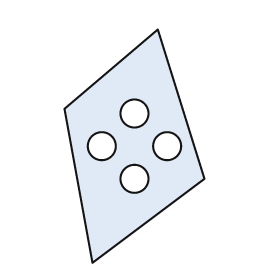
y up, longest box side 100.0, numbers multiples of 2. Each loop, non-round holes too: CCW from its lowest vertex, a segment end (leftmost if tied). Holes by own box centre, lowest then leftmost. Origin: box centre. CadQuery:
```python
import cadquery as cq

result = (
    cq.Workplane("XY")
    .moveTo(-18.0, -50.0)
    .lineTo(30.0, -14.0)
    .lineTo(10.0, 50.0)
    .lineTo(-30.0, 16.0)
    .close()
    .moveTo(0.0, -14.0)
    .circle(6.0)
    .moveTo(-14.0, 0.0)
    .circle(6.0)
    .moveTo(14.0, 0.0)
    .circle(6.0)
    .moveTo(0.0, 14.0)
    .circle(6.0)
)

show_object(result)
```